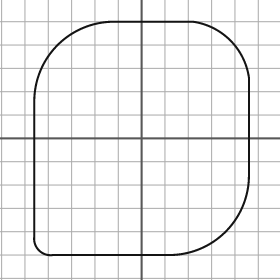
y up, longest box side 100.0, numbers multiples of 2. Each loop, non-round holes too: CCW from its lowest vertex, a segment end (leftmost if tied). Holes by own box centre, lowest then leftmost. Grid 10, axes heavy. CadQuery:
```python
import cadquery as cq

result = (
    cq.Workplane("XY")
    .moveTo(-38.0, -50.0)
    .lineTo(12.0, -50.0)
    .threePointArc((36.0, -40.0), (46.0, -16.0))
    .lineTo(46.0, 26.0)
    .threePointArc((38.0, 42.0), (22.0, 50.0))
    .lineTo(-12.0, 50.0)
    .threePointArc((-36.0, 40.0), (-46.0, 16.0))
    .lineTo(-46.0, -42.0)
    .threePointArc((-44.0, -48.0), (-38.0, -50.0))
    .close()
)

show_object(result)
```